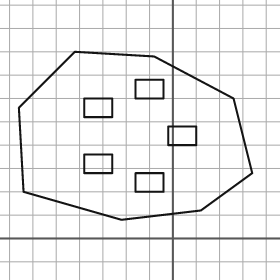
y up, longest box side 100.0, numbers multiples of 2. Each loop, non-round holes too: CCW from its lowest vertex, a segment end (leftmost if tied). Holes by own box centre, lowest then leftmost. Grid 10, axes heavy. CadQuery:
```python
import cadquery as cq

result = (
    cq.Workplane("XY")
    .moveTo(-22.0, 8.0)
    .lineTo(12.0, 12.0)
    .lineTo(34.0, 28.0)
    .lineTo(26.0, 60.0)
    .lineTo(-8.0, 78.0)
    .lineTo(-42.0, 80.0)
    .lineTo(-66.0, 56.0)
    .lineTo(-64.0, 20.0)
    .close()
    .moveTo(-16.0, 20.0)
    .lineTo(-4.0, 20.0)
    .lineTo(-4.0, 28.0)
    .lineTo(-16.0, 28.0)
    .close()
    .moveTo(-38.0, 28.0)
    .lineTo(-26.0, 28.0)
    .lineTo(-26.0, 36.0)
    .lineTo(-38.0, 36.0)
    .close()
    .moveTo(-2.0, 40.0)
    .lineTo(10.0, 40.0)
    .lineTo(10.0, 48.0)
    .lineTo(-2.0, 48.0)
    .close()
    .moveTo(-38.0, 52.0)
    .lineTo(-26.0, 52.0)
    .lineTo(-26.0, 60.0)
    .lineTo(-38.0, 60.0)
    .close()
    .moveTo(-16.0, 60.0)
    .lineTo(-4.0, 60.0)
    .lineTo(-4.0, 68.0)
    .lineTo(-16.0, 68.0)
    .close()
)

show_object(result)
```